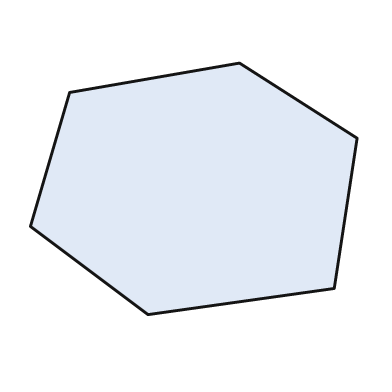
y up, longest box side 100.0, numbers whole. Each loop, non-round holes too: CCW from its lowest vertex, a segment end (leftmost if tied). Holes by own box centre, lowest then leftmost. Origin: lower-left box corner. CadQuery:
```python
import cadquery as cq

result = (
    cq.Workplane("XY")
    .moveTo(36.0, 0.0)
    .lineTo(93.0, 8.0)
    .lineTo(100.0, 54.0)
    .lineTo(64.0, 77.0)
    .lineTo(12.0, 68.0)
    .lineTo(0.0, 27.0)
    .close()
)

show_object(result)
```